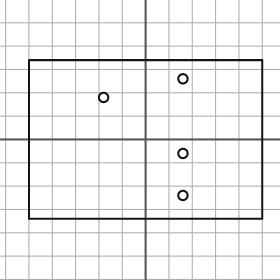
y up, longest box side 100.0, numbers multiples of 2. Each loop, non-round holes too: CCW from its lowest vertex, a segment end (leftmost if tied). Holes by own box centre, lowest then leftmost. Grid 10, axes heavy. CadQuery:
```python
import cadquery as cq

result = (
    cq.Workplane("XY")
    .moveTo(-50.0, -34.0)
    .lineTo(50.0, -34.0)
    .lineTo(50.0, 34.0)
    .lineTo(-50.0, 34.0)
    .close()
    .moveTo(16.0, -24.0)
    .circle(2.0)
    .moveTo(16.0, -6.0)
    .circle(2.0)
    .moveTo(-18.0, 18.0)
    .circle(2.0)
    .moveTo(16.0, 26.0)
    .circle(2.0)
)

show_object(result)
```